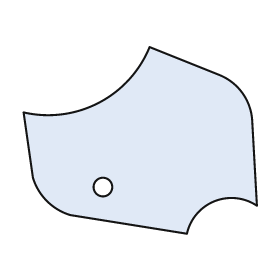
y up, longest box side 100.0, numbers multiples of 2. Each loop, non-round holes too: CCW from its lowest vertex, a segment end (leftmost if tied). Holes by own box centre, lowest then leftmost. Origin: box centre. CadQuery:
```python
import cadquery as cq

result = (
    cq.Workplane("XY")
    .moveTo(20.0, -40.0)
    .threePointArc((32.0, -26.0), (50.0, -28.0))
    .lineTo(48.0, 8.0)
    .threePointArc((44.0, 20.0), (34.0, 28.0))
    .lineTo(4.0, 40.0)
    .threePointArc((-18.0, 16.0), (-50.0, 12.0))
    .lineTo(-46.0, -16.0)
    .threePointArc((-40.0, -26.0), (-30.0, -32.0))
    .close()
    .moveTo(-16.0, -20.0)
    .circle(4.0)
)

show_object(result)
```